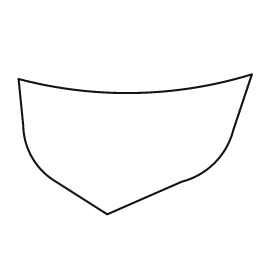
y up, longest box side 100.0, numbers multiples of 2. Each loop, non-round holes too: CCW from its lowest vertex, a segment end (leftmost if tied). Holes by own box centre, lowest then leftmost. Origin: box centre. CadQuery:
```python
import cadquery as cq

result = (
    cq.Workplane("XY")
    .moveTo(-12.0, -30.0)
    .lineTo(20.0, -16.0)
    .threePointArc((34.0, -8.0), (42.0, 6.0))
    .lineTo(50.0, 30.0)
    .threePointArc((0.0, 22.0), (-50.0, 28.0))
    .lineTo(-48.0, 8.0)
    .threePointArc((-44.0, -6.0), (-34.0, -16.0))
    .close()
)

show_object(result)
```